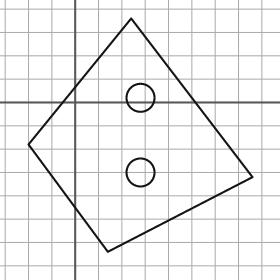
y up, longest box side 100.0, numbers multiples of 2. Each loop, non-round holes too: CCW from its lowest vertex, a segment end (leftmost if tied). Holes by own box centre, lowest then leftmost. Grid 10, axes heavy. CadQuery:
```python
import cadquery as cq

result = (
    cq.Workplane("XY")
    .moveTo(14.0, -64.0)
    .lineTo(76.0, -32.0)
    .lineTo(24.0, 36.0)
    .lineTo(-20.0, -18.0)
    .close()
    .moveTo(28.0, -30.0)
    .circle(6.0)
    .moveTo(28.0, 2.0)
    .circle(6.0)
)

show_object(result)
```